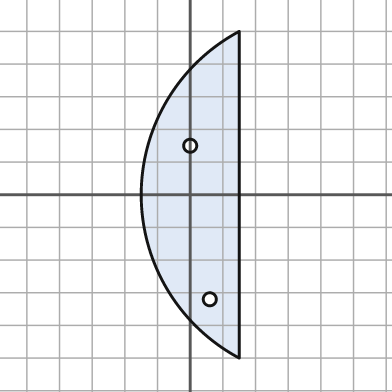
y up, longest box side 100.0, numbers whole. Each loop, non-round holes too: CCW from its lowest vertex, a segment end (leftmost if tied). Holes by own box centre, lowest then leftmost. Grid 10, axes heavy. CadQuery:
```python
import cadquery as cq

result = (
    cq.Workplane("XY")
    .moveTo(15.0, -50.0)
    .lineTo(15.0, 50.0)
    .threePointArc((-15.0, 0.0), (15.0, -50.0))
    .close()
    .moveTo(6.0, -32.0)
    .circle(2.0)
    .moveTo(0.0, 15.0)
    .circle(2.0)
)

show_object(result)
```